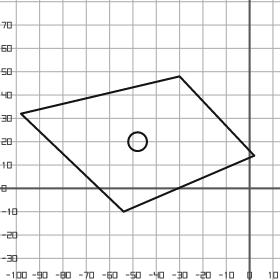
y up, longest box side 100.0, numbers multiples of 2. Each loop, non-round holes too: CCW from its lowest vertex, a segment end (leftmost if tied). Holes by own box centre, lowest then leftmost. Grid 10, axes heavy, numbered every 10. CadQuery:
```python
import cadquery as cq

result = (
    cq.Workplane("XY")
    .moveTo(-54.0, -10.0)
    .lineTo(2.0, 14.0)
    .lineTo(-30.0, 48.0)
    .lineTo(-98.0, 32.0)
    .close()
    .moveTo(-48.0, 20.0)
    .circle(4.0)
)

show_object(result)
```